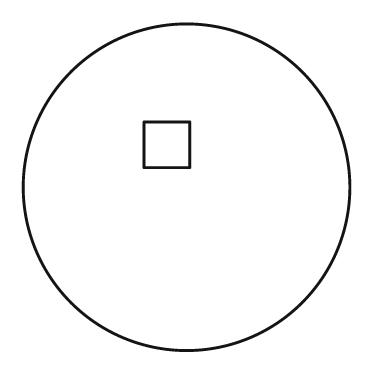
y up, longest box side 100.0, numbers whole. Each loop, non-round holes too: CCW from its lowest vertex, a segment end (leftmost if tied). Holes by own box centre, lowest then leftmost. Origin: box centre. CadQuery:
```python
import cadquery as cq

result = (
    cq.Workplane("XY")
    .moveTo(0.0, 0.0)
    .circle(50.0)
    .moveTo(-13.0, 6.0)
    .lineTo(1.0, 6.0)
    .lineTo(1.0, 20.0)
    .lineTo(-13.0, 20.0)
    .close()
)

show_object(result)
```